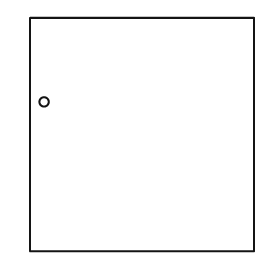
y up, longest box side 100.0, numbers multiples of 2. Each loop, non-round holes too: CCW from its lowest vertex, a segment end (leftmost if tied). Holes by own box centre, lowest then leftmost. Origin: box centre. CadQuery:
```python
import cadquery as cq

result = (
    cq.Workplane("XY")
    .moveTo(-48.0, -50.0)
    .lineTo(48.0, -50.0)
    .lineTo(48.0, 50.0)
    .lineTo(-48.0, 50.0)
    .close()
    .moveTo(-42.0, 14.0)
    .circle(2.0)
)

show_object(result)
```